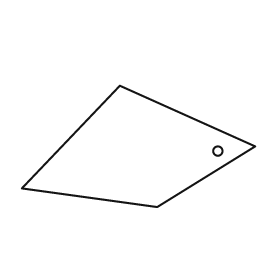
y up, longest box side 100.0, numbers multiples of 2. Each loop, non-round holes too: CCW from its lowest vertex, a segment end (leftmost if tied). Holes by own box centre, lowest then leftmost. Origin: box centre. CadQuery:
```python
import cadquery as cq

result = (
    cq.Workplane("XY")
    .moveTo(8.0, -26.0)
    .lineTo(50.0, 0.0)
    .lineTo(-8.0, 26.0)
    .lineTo(-50.0, -18.0)
    .close()
    .moveTo(34.0, -2.0)
    .circle(2.0)
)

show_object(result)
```